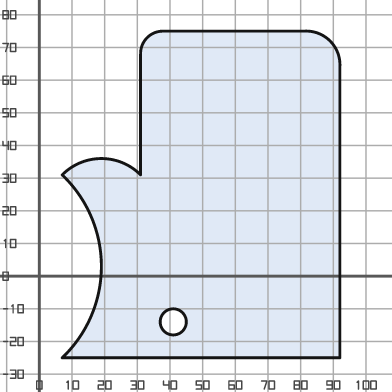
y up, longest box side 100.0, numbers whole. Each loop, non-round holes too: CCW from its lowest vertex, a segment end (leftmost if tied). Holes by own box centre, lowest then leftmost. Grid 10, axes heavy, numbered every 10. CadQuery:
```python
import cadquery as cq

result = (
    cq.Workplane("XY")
    .moveTo(7.0, -25.0)
    .lineTo(92.0, -25.0)
    .lineTo(92.0, 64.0)
    .threePointArc((89.0, 72.0), (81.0, 75.0))
    .lineTo(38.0, 75.0)
    .threePointArc((33.0, 73.0), (31.0, 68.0))
    .lineTo(31.0, 31.0)
    .threePointArc((19.0, 36.0), (7.0, 31.0))
    .threePointArc((19.0, 3.0), (7.0, -25.0))
    .close()
    .moveTo(41.0, -14.0)
    .circle(4.0)
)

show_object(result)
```